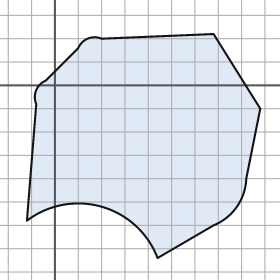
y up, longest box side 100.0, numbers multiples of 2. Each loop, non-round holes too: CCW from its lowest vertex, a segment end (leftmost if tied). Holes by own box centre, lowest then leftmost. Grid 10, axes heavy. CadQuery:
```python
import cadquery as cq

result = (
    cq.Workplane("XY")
    .moveTo(44.0, -74.0)
    .lineTo(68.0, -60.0)
    .threePointArc((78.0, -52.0), (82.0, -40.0))
    .lineTo(88.0, -10.0)
    .lineTo(68.0, 22.0)
    .lineTo(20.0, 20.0)
    .threePointArc((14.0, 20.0), (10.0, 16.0))
    .lineTo(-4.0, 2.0)
    .threePointArc((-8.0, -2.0), (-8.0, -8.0))
    .lineTo(-12.0, -58.0)
    .threePointArc((20.0, -52.0), (44.0, -74.0))
    .close()
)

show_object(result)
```